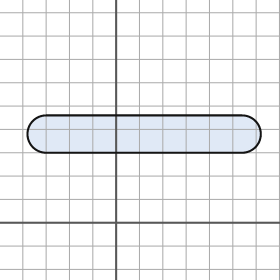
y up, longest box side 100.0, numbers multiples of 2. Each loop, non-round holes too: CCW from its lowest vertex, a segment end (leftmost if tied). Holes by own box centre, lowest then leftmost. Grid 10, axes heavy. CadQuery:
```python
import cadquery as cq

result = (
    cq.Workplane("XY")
    .moveTo(-30.0, 30.0)
    .lineTo(54.0, 30.0)
    .threePointArc((62.0, 38.0), (54.0, 46.0))
    .lineTo(-30.0, 46.0)
    .threePointArc((-38.0, 38.0), (-30.0, 30.0))
    .close()
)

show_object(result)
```